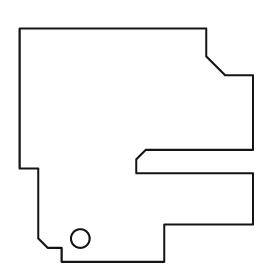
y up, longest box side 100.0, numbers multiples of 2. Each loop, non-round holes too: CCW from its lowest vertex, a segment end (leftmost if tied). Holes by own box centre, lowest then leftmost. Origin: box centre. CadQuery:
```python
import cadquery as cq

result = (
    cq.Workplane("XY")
    .moveTo(-32.0, -50.0)
    .lineTo(12.0, -50.0)
    .lineTo(12.0, -34.0)
    .lineTo(50.0, -34.0)
    .lineTo(50.0, -12.0)
    .lineTo(0.0, -12.0)
    .lineTo(0.0, -6.0)
    .lineTo(4.0, -2.0)
    .lineTo(50.0, -2.0)
    .lineTo(50.0, 30.0)
    .lineTo(38.0, 30.0)
    .lineTo(30.0, 38.0)
    .lineTo(30.0, 50.0)
    .lineTo(-50.0, 50.0)
    .lineTo(-50.0, -10.0)
    .lineTo(-42.0, -10.0)
    .lineTo(-42.0, -40.0)
    .lineTo(-38.0, -44.0)
    .lineTo(-32.0, -44.0)
    .close()
    .moveTo(-24.0, -40.0)
    .circle(4.0)
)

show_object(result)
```